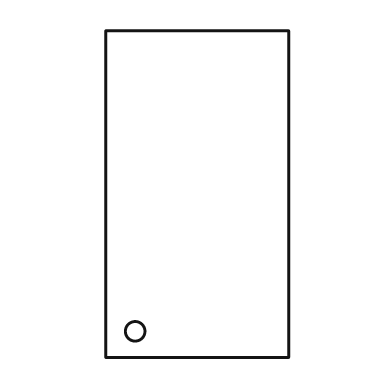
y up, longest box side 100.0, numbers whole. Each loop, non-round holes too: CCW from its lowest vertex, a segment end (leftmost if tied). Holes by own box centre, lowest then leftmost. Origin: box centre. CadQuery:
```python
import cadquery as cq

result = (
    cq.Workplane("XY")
    .moveTo(-28.0, -50.0)
    .lineTo(28.0, -50.0)
    .lineTo(28.0, 50.0)
    .lineTo(-28.0, 50.0)
    .close()
    .moveTo(-19.0, -42.0)
    .circle(3.0)
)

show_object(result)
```